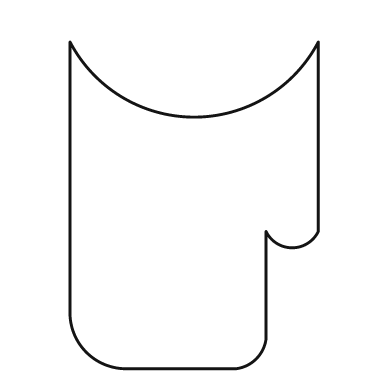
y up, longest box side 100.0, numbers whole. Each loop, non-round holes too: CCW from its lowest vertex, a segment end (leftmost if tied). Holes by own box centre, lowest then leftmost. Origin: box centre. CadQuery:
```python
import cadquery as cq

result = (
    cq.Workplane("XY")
    .moveTo(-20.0, -50.0)
    .lineTo(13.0, -50.0)
    .threePointArc((19.0, -47.0), (22.0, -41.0))
    .lineTo(22.0, -8.0)
    .threePointArc((30.0, -13.0), (38.0, -8.0))
    .lineTo(38.0, 50.0)
    .threePointArc((0.0, 27.0), (-38.0, 50.0))
    .lineTo(-38.0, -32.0)
    .threePointArc((-33.0, -45.0), (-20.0, -50.0))
    .close()
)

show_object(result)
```